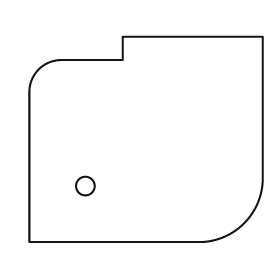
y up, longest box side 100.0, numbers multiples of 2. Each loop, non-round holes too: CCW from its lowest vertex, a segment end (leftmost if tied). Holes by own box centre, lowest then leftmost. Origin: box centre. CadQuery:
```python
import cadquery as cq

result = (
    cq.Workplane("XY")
    .moveTo(-50.0, -44.0)
    .lineTo(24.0, -44.0)
    .threePointArc((42.0, -36.0), (50.0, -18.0))
    .lineTo(50.0, 44.0)
    .lineTo(-10.0, 44.0)
    .lineTo(-10.0, 34.0)
    .lineTo(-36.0, 34.0)
    .threePointArc((-46.0, 30.0), (-50.0, 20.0))
    .close()
    .moveTo(-26.0, -20.0)
    .circle(4.0)
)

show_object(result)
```